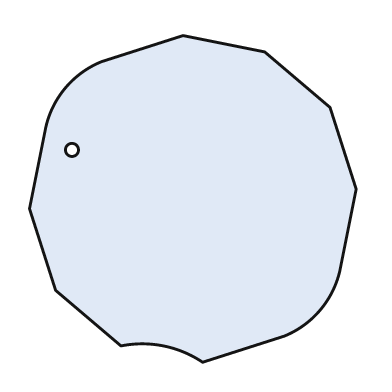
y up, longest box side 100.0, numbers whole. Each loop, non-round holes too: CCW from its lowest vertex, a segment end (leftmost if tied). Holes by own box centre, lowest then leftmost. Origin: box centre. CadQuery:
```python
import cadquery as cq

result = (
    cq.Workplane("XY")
    .moveTo(3.0, -50.0)
    .lineTo(28.0, -42.0)
    .threePointArc((39.0, -34.0), (45.0, -22.0))
    .lineTo(50.0, 3.0)
    .lineTo(42.0, 28.0)
    .lineTo(22.0, 45.0)
    .lineTo(-3.0, 50.0)
    .lineTo(-28.0, 42.0)
    .threePointArc((-39.0, 34.0), (-45.0, 22.0))
    .lineTo(-50.0, -3.0)
    .lineTo(-42.0, -28.0)
    .lineTo(-22.0, -45.0)
    .threePointArc((-9.0, -45.0), (3.0, -50.0))
    .close()
    .moveTo(-37.0, 15.0)
    .circle(2.0)
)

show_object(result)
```